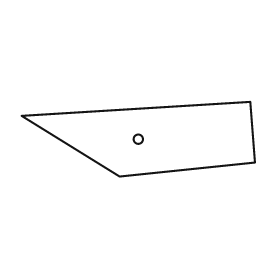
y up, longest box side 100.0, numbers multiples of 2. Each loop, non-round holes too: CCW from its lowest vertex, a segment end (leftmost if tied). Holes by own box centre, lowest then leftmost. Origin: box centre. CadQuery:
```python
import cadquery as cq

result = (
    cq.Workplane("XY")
    .moveTo(-8.0, -16.0)
    .lineTo(50.0, -10.0)
    .lineTo(48.0, 16.0)
    .lineTo(-50.0, 10.0)
    .close()
    .moveTo(0.0, 0.0)
    .circle(2.0)
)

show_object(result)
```